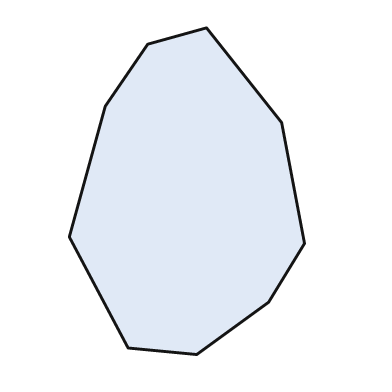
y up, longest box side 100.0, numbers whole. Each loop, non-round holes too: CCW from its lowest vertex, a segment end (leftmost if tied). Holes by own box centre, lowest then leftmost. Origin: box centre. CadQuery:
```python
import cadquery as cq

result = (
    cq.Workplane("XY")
    .moveTo(3.0, -50.0)
    .lineTo(25.0, -34.0)
    .lineTo(36.0, -16.0)
    .lineTo(29.0, 21.0)
    .lineTo(6.0, 50.0)
    .lineTo(-12.0, 45.0)
    .lineTo(-25.0, 26.0)
    .lineTo(-36.0, -14.0)
    .lineTo(-18.0, -48.0)
    .close()
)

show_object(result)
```